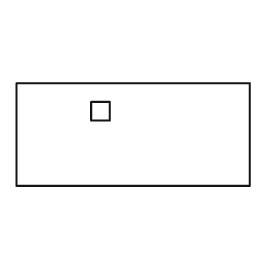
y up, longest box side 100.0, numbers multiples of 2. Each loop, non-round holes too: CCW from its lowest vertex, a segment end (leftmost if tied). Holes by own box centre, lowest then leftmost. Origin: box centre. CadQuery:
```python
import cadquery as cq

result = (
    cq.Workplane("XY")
    .moveTo(-50.0, -22.0)
    .lineTo(50.0, -22.0)
    .lineTo(50.0, 22.0)
    .lineTo(-50.0, 22.0)
    .close()
    .moveTo(-18.0, 6.0)
    .lineTo(-10.0, 6.0)
    .lineTo(-10.0, 14.0)
    .lineTo(-18.0, 14.0)
    .close()
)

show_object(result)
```